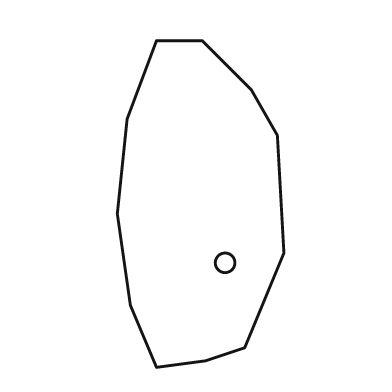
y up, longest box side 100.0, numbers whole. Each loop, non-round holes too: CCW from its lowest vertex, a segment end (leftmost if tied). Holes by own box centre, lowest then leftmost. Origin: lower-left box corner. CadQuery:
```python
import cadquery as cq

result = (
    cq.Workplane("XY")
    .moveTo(12.0, 0.0)
    .lineTo(27.0, 2.0)
    .lineTo(39.0, 6.0)
    .lineTo(51.0, 35.0)
    .lineTo(49.0, 71.0)
    .lineTo(41.0, 85.0)
    .lineTo(26.0, 100.0)
    .lineTo(12.0, 100.0)
    .lineTo(3.0, 76.0)
    .lineTo(0.0, 47.0)
    .lineTo(4.0, 19.0)
    .close()
    .moveTo(33.0, 32.0)
    .circle(3.0)
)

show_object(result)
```